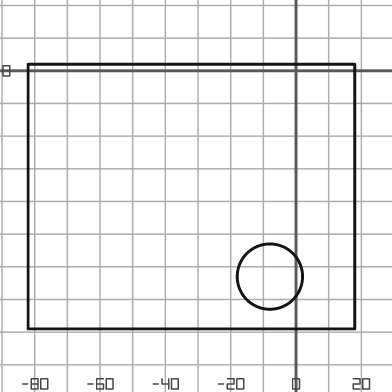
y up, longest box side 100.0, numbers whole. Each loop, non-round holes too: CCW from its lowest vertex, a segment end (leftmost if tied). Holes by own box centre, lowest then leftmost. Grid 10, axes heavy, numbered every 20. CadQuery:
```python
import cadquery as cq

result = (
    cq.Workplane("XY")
    .moveTo(-82.0, -79.0)
    .lineTo(18.0, -79.0)
    .lineTo(18.0, 2.0)
    .lineTo(-82.0, 2.0)
    .close()
    .moveTo(-8.0, -63.0)
    .circle(10.0)
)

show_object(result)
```